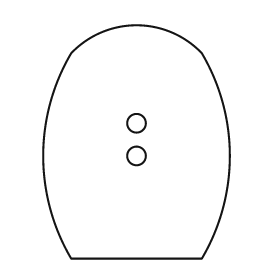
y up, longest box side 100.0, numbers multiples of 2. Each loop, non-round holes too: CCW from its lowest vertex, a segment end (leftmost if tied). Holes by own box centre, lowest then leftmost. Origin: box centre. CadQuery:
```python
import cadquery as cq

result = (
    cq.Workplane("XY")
    .moveTo(-28.0, -50.0)
    .lineTo(28.0, -50.0)
    .threePointArc((40.0, -6.0), (28.0, 38.0))
    .threePointArc((0.0, 50.0), (-28.0, 38.0))
    .threePointArc((-40.0, -6.0), (-28.0, -50.0))
    .close()
    .moveTo(0.0, -6.0)
    .circle(4.0)
    .moveTo(0.0, 8.0)
    .circle(4.0)
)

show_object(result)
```